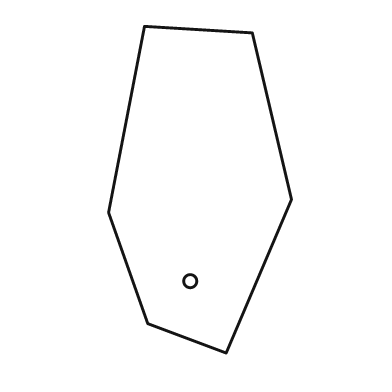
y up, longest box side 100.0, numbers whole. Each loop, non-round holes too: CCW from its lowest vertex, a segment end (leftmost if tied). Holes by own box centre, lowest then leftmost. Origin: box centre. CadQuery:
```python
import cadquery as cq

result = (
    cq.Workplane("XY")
    .moveTo(8.0, -50.0)
    .lineTo(28.0, -3.0)
    .lineTo(16.0, 48.0)
    .lineTo(-17.0, 50.0)
    .lineTo(-28.0, -7.0)
    .lineTo(-16.0, -41.0)
    .close()
    .moveTo(-3.0, -28.0)
    .circle(2.0)
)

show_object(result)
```